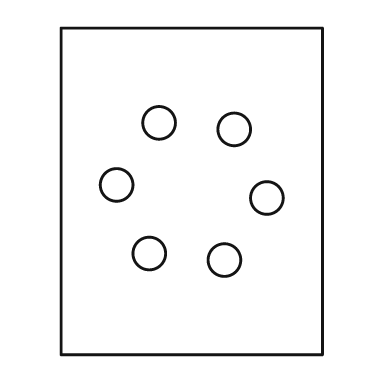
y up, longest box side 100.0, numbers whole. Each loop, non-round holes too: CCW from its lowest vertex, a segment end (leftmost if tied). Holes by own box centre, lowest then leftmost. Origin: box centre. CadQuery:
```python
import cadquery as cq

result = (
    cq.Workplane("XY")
    .moveTo(-40.0, -50.0)
    .lineTo(40.0, -50.0)
    .lineTo(40.0, 50.0)
    .lineTo(-40.0, 50.0)
    .close()
    .moveTo(10.0, -21.0)
    .circle(5.0)
    .moveTo(-13.0, -19.0)
    .circle(5.0)
    .moveTo(23.0, -2.0)
    .circle(5.0)
    .moveTo(-23.0, 2.0)
    .circle(5.0)
    .moveTo(13.0, 19.0)
    .circle(5.0)
    .moveTo(-10.0, 21.0)
    .circle(5.0)
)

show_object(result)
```